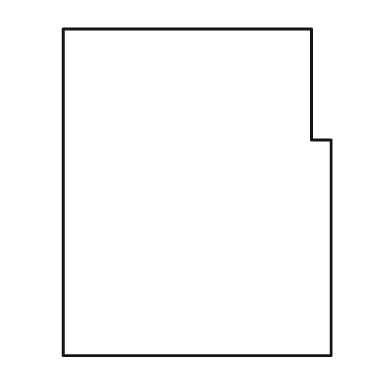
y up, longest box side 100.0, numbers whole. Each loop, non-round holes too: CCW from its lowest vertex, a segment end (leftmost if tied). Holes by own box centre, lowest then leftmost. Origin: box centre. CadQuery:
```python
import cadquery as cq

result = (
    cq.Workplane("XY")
    .moveTo(-41.0, -50.0)
    .lineTo(41.0, -50.0)
    .lineTo(41.0, 16.0)
    .lineTo(35.0, 16.0)
    .lineTo(35.0, 50.0)
    .lineTo(-41.0, 50.0)
    .close()
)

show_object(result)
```